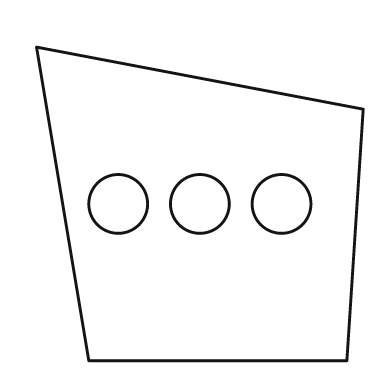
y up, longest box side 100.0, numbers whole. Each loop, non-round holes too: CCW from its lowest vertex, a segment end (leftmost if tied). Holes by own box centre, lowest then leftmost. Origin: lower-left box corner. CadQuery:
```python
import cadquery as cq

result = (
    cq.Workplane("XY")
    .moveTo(16.0, 0.0)
    .lineTo(95.0, 0.0)
    .lineTo(100.0, 77.0)
    .lineTo(0.0, 96.0)
    .close()
    .moveTo(25.0, 48.0)
    .circle(9.0)
    .moveTo(50.0, 48.0)
    .circle(9.0)
    .moveTo(75.0, 48.0)
    .circle(9.0)
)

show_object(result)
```